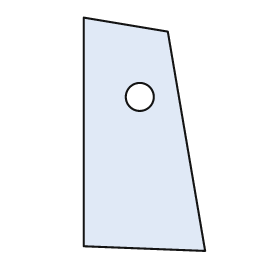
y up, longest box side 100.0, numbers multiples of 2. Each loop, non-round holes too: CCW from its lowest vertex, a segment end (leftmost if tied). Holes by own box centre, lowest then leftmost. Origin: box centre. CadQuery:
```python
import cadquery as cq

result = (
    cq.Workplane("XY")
    .moveTo(26.0, -50.0)
    .lineTo(10.0, 44.0)
    .lineTo(-26.0, 50.0)
    .lineTo(-26.0, -48.0)
    .close()
    .moveTo(-2.0, 16.0)
    .circle(6.0)
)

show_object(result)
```